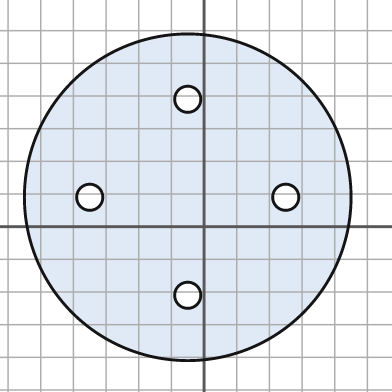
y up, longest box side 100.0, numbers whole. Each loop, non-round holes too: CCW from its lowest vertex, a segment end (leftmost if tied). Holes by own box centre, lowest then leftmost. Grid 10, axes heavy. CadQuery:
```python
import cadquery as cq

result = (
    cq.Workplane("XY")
    .moveTo(-5.0, 9.0)
    .circle(50.0)
    .moveTo(-5.0, -21.0)
    .circle(4.0)
    .moveTo(-35.0, 9.0)
    .circle(4.0)
    .moveTo(25.0, 9.0)
    .circle(4.0)
    .moveTo(-5.0, 39.0)
    .circle(4.0)
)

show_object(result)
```